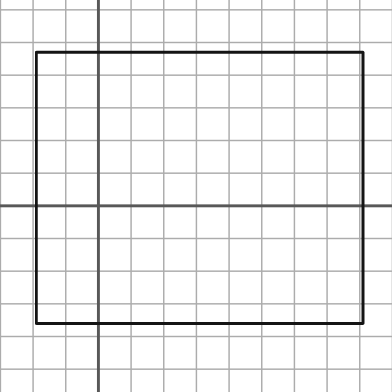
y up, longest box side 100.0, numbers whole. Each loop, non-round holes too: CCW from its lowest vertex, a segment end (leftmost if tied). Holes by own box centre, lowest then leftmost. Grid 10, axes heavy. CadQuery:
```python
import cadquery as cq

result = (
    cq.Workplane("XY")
    .moveTo(-19.0, -36.0)
    .lineTo(81.0, -36.0)
    .lineTo(81.0, 47.0)
    .lineTo(-19.0, 47.0)
    .close()
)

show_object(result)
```